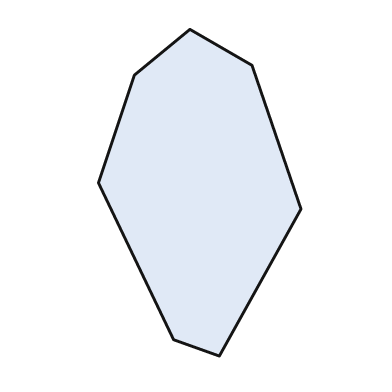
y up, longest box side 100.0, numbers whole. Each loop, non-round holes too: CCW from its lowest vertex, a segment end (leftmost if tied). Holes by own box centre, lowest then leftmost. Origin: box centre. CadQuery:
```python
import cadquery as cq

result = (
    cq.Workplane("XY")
    .moveTo(6.0, -50.0)
    .lineTo(31.0, -5.0)
    .lineTo(16.0, 39.0)
    .lineTo(-3.0, 50.0)
    .lineTo(-20.0, 36.0)
    .lineTo(-31.0, 3.0)
    .lineTo(-8.0, -45.0)
    .close()
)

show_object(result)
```